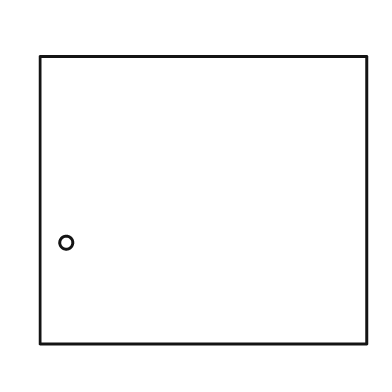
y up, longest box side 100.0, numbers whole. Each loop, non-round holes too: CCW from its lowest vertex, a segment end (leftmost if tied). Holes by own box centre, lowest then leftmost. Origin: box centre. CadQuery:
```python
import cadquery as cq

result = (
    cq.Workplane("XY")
    .moveTo(-50.0, -44.0)
    .lineTo(50.0, -44.0)
    .lineTo(50.0, 44.0)
    .lineTo(-50.0, 44.0)
    .close()
    .moveTo(-42.0, -13.0)
    .circle(2.0)
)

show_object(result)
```